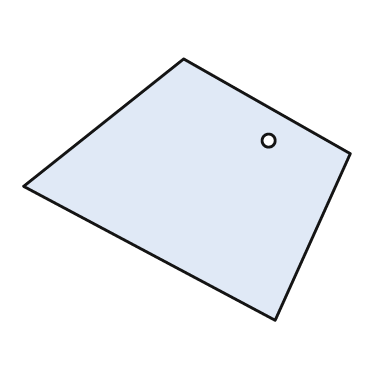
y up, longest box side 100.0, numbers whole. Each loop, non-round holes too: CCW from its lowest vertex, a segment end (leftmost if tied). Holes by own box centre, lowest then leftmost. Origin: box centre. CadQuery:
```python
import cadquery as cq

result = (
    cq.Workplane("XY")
    .moveTo(27.0, -40.0)
    .lineTo(50.0, 11.0)
    .lineTo(-1.0, 40.0)
    .lineTo(-50.0, 1.0)
    .close()
    .moveTo(25.0, 15.0)
    .circle(2.0)
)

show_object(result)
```